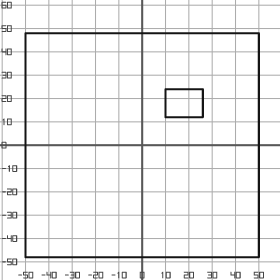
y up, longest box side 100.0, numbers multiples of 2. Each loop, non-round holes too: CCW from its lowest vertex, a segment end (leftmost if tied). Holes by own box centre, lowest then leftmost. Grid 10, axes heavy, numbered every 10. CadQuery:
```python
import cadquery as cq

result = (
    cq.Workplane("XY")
    .moveTo(-50.0, -48.0)
    .lineTo(50.0, -48.0)
    .lineTo(50.0, 48.0)
    .lineTo(-50.0, 48.0)
    .close()
    .moveTo(10.0, 12.0)
    .lineTo(26.0, 12.0)
    .lineTo(26.0, 24.0)
    .lineTo(10.0, 24.0)
    .close()
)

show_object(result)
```